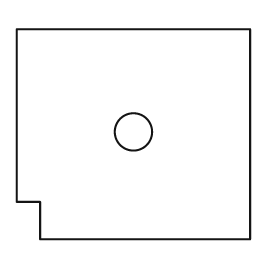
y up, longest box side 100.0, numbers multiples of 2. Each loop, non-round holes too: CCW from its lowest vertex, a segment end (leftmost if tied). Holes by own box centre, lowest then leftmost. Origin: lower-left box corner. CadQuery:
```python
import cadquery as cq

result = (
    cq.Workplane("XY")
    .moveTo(10.0, 0.0)
    .lineTo(100.0, 0.0)
    .lineTo(100.0, 90.0)
    .lineTo(0.0, 90.0)
    .lineTo(0.0, 16.0)
    .lineTo(10.0, 16.0)
    .close()
    .moveTo(50.0, 46.0)
    .circle(8.0)
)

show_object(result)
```